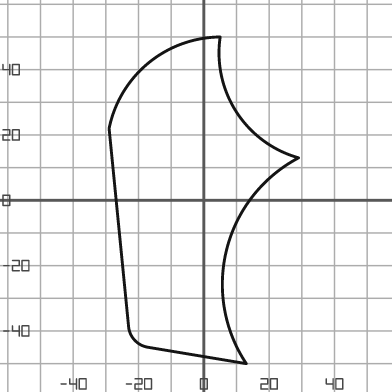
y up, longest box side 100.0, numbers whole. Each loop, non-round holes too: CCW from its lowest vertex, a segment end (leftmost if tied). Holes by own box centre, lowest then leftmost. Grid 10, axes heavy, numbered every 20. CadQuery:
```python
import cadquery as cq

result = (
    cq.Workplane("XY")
    .moveTo(13.0, -50.0)
    .threePointArc((7.0, -15.0), (29.0, 13.0))
    .threePointArc((10.0, 27.0), (5.0, 50.0))
    .threePointArc((-17.0, 42.0), (-29.0, 22.0))
    .lineTo(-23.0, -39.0)
    .threePointArc((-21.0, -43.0), (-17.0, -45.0))
    .close()
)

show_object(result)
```